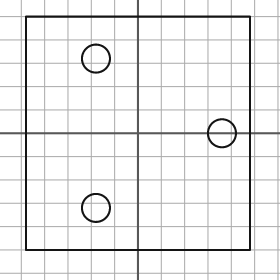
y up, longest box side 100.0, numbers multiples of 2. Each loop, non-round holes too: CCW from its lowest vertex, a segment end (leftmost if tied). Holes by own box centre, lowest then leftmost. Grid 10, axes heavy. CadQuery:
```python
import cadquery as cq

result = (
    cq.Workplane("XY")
    .moveTo(-48.0, -50.0)
    .lineTo(48.0, -50.0)
    .lineTo(48.0, 50.0)
    .lineTo(-48.0, 50.0)
    .close()
    .moveTo(-18.0, -32.0)
    .circle(6.0)
    .moveTo(36.0, 0.0)
    .circle(6.0)
    .moveTo(-18.0, 32.0)
    .circle(6.0)
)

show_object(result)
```